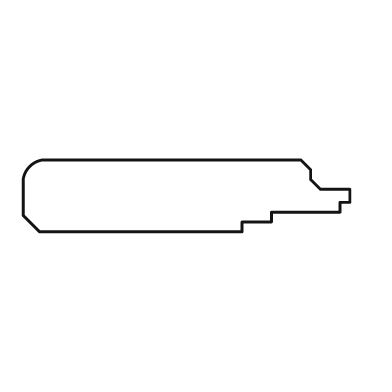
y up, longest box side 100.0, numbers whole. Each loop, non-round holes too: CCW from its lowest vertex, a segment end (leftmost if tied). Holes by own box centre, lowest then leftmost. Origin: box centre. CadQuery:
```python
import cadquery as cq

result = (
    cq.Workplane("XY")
    .moveTo(-45.0, -11.0)
    .lineTo(17.0, -11.0)
    .lineTo(17.0, -8.0)
    .lineTo(26.0, -8.0)
    .lineTo(26.0, -5.0)
    .lineTo(47.0, -5.0)
    .lineTo(47.0, -2.0)
    .lineTo(50.0, -2.0)
    .lineTo(50.0, 2.0)
    .lineTo(41.0, 2.0)
    .lineTo(38.0, 5.0)
    .lineTo(38.0, 8.0)
    .lineTo(35.0, 11.0)
    .lineTo(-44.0, 11.0)
    .threePointArc((-48.0, 9.0), (-50.0, 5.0))
    .lineTo(-50.0, -6.0)
    .close()
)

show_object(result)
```